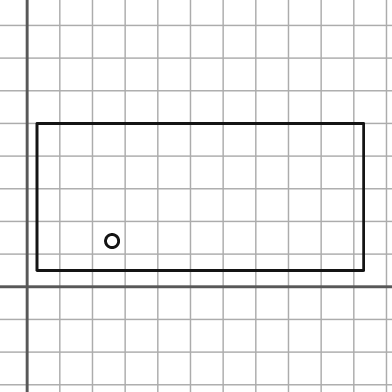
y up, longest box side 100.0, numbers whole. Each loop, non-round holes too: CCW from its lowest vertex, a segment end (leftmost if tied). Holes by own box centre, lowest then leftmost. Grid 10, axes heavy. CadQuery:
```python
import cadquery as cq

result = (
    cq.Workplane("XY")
    .moveTo(3.0, 5.0)
    .lineTo(103.0, 5.0)
    .lineTo(103.0, 50.0)
    .lineTo(3.0, 50.0)
    .close()
    .moveTo(26.0, 14.0)
    .circle(2.0)
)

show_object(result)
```